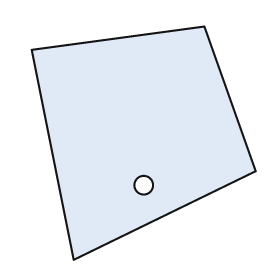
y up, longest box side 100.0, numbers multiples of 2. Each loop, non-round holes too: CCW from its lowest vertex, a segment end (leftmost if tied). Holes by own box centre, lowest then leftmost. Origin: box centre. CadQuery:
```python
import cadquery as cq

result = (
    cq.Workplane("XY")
    .moveTo(-30.0, -50.0)
    .lineTo(48.0, -12.0)
    .lineTo(26.0, 50.0)
    .lineTo(-48.0, 40.0)
    .close()
    .moveTo(0.0, -18.0)
    .circle(4.0)
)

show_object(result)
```